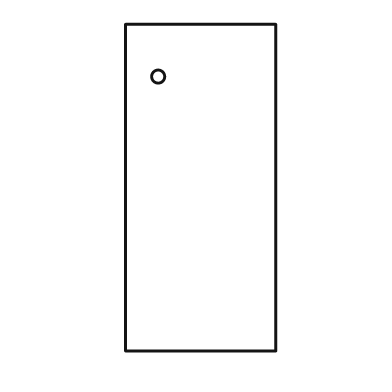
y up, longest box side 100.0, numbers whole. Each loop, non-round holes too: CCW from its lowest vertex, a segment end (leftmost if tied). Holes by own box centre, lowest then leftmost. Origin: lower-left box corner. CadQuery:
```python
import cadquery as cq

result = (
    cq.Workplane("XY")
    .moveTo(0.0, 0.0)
    .lineTo(46.0, 0.0)
    .lineTo(46.0, 100.0)
    .lineTo(0.0, 100.0)
    .close()
    .moveTo(10.0, 84.0)
    .circle(2.0)
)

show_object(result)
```